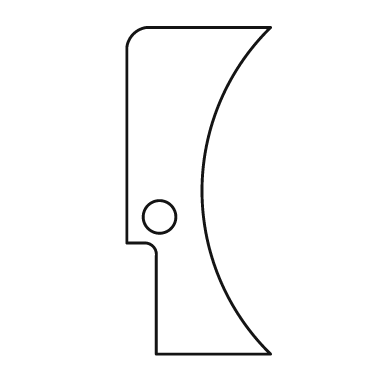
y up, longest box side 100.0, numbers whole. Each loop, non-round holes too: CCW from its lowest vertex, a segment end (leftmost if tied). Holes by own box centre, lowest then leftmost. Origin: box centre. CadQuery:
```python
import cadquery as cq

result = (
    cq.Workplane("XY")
    .moveTo(-13.0, -50.0)
    .lineTo(22.0, -50.0)
    .threePointArc((1.0, 0.0), (22.0, 50.0))
    .lineTo(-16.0, 50.0)
    .threePointArc((-20.0, 48.0), (-22.0, 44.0))
    .lineTo(-22.0, -16.0)
    .lineTo(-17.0, -16.0)
    .threePointArc((-14.0, -17.0), (-13.0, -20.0))
    .close()
    .moveTo(-12.0, -8.0)
    .circle(5.0)
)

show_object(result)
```